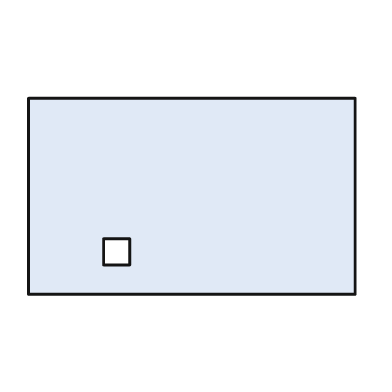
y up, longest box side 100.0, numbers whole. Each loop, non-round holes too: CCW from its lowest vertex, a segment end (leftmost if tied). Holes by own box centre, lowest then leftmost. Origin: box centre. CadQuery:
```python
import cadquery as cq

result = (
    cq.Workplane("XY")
    .moveTo(-50.0, -30.0)
    .lineTo(50.0, -30.0)
    .lineTo(50.0, 30.0)
    .lineTo(-50.0, 30.0)
    .close()
    .moveTo(-27.0, -21.0)
    .lineTo(-19.0, -21.0)
    .lineTo(-19.0, -13.0)
    .lineTo(-27.0, -13.0)
    .close()
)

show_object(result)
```